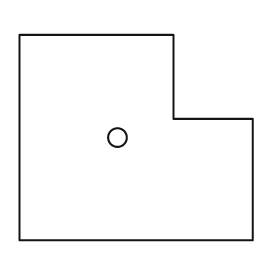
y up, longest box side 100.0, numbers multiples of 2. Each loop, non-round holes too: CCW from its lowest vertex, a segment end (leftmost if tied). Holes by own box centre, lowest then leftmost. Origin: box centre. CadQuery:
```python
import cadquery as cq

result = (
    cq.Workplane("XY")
    .moveTo(-50.0, -44.0)
    .lineTo(50.0, -44.0)
    .lineTo(50.0, 8.0)
    .lineTo(16.0, 8.0)
    .lineTo(16.0, 44.0)
    .lineTo(-50.0, 44.0)
    .close()
    .moveTo(-8.0, 0.0)
    .circle(4.0)
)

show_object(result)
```